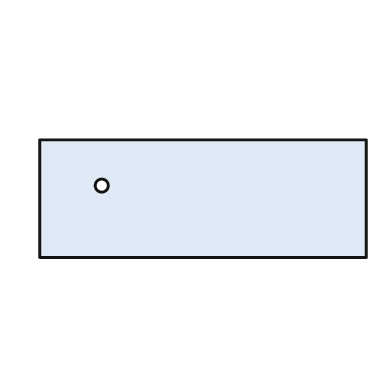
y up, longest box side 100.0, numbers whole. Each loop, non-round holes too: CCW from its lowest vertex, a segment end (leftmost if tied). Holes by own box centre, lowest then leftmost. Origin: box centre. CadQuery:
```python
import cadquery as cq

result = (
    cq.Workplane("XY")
    .moveTo(-50.0, -18.0)
    .lineTo(50.0, -18.0)
    .lineTo(50.0, 18.0)
    .lineTo(-50.0, 18.0)
    .close()
    .moveTo(-31.0, 4.0)
    .circle(2.0)
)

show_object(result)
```